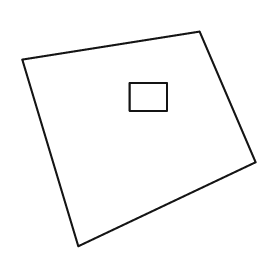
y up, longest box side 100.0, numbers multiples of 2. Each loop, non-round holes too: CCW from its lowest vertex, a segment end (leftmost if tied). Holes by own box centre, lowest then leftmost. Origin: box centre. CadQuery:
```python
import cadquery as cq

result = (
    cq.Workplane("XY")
    .moveTo(-26.0, -46.0)
    .lineTo(50.0, -10.0)
    .lineTo(26.0, 46.0)
    .lineTo(-50.0, 34.0)
    .close()
    .moveTo(-4.0, 12.0)
    .lineTo(12.0, 12.0)
    .lineTo(12.0, 24.0)
    .lineTo(-4.0, 24.0)
    .close()
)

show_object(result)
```